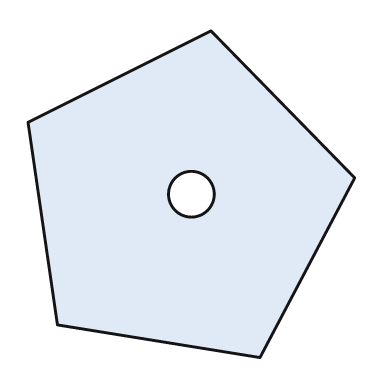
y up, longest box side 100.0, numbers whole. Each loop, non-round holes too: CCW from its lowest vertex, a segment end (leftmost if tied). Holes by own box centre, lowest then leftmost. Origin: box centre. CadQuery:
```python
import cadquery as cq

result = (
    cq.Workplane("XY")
    .moveTo(21.0, -50.0)
    .lineTo(50.0, 5.0)
    .lineTo(6.0, 50.0)
    .lineTo(-50.0, 22.0)
    .lineTo(-41.0, -40.0)
    .close()
    .moveTo(0.0, 0.0)
    .circle(7.0)
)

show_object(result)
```